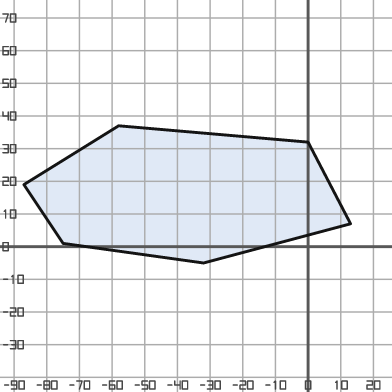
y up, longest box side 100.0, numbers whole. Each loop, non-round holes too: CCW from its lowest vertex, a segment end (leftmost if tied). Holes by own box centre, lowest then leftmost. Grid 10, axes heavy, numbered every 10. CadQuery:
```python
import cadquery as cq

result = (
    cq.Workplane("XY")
    .moveTo(-32.0, -5.0)
    .lineTo(13.0, 7.0)
    .lineTo(0.0, 32.0)
    .lineTo(-58.0, 37.0)
    .lineTo(-87.0, 19.0)
    .lineTo(-75.0, 1.0)
    .close()
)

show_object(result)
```